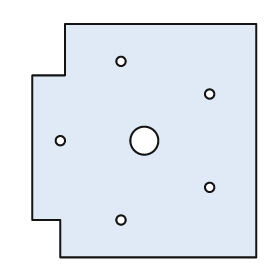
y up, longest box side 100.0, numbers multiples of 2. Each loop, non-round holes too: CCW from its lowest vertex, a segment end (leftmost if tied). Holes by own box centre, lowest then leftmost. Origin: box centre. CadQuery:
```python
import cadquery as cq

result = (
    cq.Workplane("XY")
    .moveTo(-36.0, -50.0)
    .lineTo(48.0, -50.0)
    .lineTo(48.0, 50.0)
    .lineTo(-34.0, 50.0)
    .lineTo(-34.0, 28.0)
    .lineTo(-48.0, 28.0)
    .lineTo(-48.0, -34.0)
    .lineTo(-36.0, -34.0)
    .close()
    .moveTo(-10.0, -34.0)
    .circle(2.0)
    .moveTo(28.0, -20.0)
    .circle(2.0)
    .moveTo(-36.0, 0.0)
    .circle(2.0)
    .moveTo(0.0, 0.0)
    .circle(6.0)
    .moveTo(28.0, 20.0)
    .circle(2.0)
    .moveTo(-10.0, 34.0)
    .circle(2.0)
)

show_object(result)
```